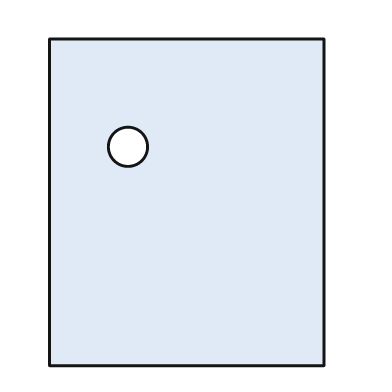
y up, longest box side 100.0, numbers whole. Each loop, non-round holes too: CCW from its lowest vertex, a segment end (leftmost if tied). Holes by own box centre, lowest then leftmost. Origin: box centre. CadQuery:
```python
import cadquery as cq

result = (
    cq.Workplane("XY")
    .moveTo(-42.0, -50.0)
    .lineTo(42.0, -50.0)
    .lineTo(42.0, 50.0)
    .lineTo(-42.0, 50.0)
    .close()
    .moveTo(-18.0, 17.0)
    .circle(6.0)
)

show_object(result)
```